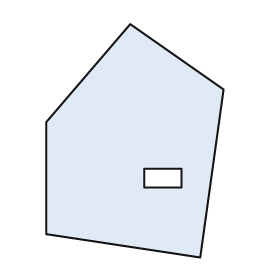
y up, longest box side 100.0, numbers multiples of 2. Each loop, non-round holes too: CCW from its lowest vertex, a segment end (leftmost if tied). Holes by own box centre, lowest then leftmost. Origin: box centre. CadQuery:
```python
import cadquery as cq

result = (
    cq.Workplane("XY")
    .moveTo(28.0, -50.0)
    .lineTo(38.0, 22.0)
    .lineTo(-2.0, 50.0)
    .lineTo(-38.0, 8.0)
    .lineTo(-38.0, -40.0)
    .close()
    .moveTo(4.0, -20.0)
    .lineTo(20.0, -20.0)
    .lineTo(20.0, -12.0)
    .lineTo(4.0, -12.0)
    .close()
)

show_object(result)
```